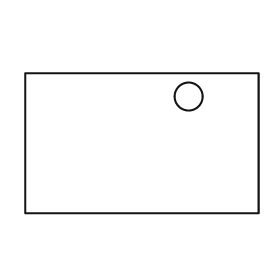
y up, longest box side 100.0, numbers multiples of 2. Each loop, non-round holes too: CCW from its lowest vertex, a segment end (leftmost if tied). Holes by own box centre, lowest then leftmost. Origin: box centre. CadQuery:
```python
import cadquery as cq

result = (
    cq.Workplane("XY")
    .moveTo(-50.0, -30.0)
    .lineTo(50.0, -30.0)
    .lineTo(50.0, 30.0)
    .lineTo(-50.0, 30.0)
    .close()
    .moveTo(20.0, 20.0)
    .circle(6.0)
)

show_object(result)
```